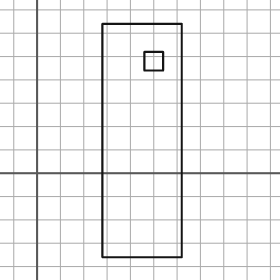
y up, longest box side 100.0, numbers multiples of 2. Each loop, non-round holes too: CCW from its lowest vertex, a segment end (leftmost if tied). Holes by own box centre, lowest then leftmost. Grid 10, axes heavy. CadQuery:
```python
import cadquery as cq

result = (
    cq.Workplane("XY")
    .moveTo(28.0, -36.0)
    .lineTo(62.0, -36.0)
    .lineTo(62.0, 64.0)
    .lineTo(28.0, 64.0)
    .close()
    .moveTo(46.0, 44.0)
    .lineTo(54.0, 44.0)
    .lineTo(54.0, 52.0)
    .lineTo(46.0, 52.0)
    .close()
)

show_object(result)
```